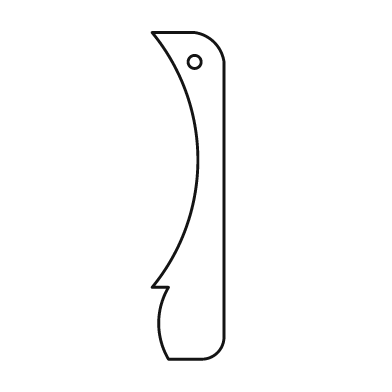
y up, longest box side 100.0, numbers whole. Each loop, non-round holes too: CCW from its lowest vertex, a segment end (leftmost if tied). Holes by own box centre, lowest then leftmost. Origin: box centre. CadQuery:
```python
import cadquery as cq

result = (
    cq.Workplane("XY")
    .moveTo(-6.0, -50.0)
    .lineTo(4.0, -50.0)
    .threePointArc((9.0, -48.0), (11.0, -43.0))
    .lineTo(11.0, 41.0)
    .threePointArc((8.0, 47.0), (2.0, 50.0))
    .lineTo(-11.0, 50.0)
    .threePointArc((3.0, 11.0), (-11.0, -28.0))
    .lineTo(-6.0, -28.0)
    .threePointArc((-9.0, -39.0), (-6.0, -50.0))
    .close()
    .moveTo(2.0, 41.0)
    .circle(2.0)
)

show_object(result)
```